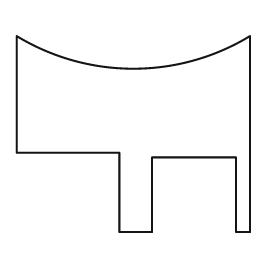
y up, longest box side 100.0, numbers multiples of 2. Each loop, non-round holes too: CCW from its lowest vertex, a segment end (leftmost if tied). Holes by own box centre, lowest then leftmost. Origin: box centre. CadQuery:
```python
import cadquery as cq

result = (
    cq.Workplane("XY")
    .moveTo(-6.0, -42.0)
    .lineTo(8.0, -42.0)
    .lineTo(8.0, -10.0)
    .lineTo(44.0, -10.0)
    .lineTo(44.0, -42.0)
    .lineTo(50.0, -42.0)
    .lineTo(50.0, 42.0)
    .threePointArc((0.0, 28.0), (-50.0, 42.0))
    .lineTo(-50.0, -8.0)
    .lineTo(-6.0, -8.0)
    .close()
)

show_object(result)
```